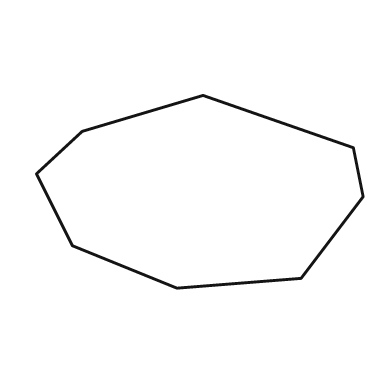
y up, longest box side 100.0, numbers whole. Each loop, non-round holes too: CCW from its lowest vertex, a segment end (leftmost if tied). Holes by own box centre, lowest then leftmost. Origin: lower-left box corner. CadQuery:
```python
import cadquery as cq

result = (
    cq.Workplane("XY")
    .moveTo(43.0, 0.0)
    .lineTo(81.0, 3.0)
    .lineTo(100.0, 28.0)
    .lineTo(97.0, 43.0)
    .lineTo(51.0, 59.0)
    .lineTo(14.0, 48.0)
    .lineTo(0.0, 35.0)
    .lineTo(11.0, 13.0)
    .close()
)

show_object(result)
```